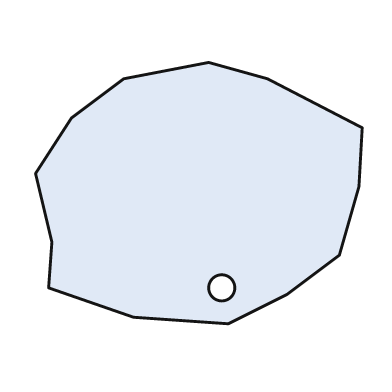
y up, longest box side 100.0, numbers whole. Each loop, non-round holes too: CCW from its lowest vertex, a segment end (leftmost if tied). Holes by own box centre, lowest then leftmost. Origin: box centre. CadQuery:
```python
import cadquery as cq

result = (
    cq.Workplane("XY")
    .moveTo(9.0, -40.0)
    .lineTo(27.0, -31.0)
    .lineTo(43.0, -19.0)
    .lineTo(49.0, 2.0)
    .lineTo(50.0, 20.0)
    .lineTo(21.0, 35.0)
    .lineTo(3.0, 40.0)
    .lineTo(-23.0, 35.0)
    .lineTo(-39.0, 23.0)
    .lineTo(-50.0, 6.0)
    .lineTo(-45.0, -15.0)
    .lineTo(-46.0, -29.0)
    .lineTo(-20.0, -38.0)
    .close()
    .moveTo(7.0, -29.0)
    .circle(4.0)
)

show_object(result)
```